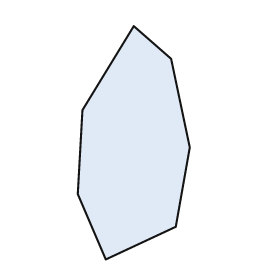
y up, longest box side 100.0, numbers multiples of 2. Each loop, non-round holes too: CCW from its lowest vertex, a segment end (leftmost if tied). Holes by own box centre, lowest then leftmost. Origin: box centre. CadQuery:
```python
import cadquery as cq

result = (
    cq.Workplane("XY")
    .moveTo(-12.0, -50.0)
    .lineTo(18.0, -36.0)
    .lineTo(24.0, -2.0)
    .lineTo(16.0, 36.0)
    .lineTo(0.0, 50.0)
    .lineTo(-22.0, 14.0)
    .lineTo(-24.0, -22.0)
    .close()
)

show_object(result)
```